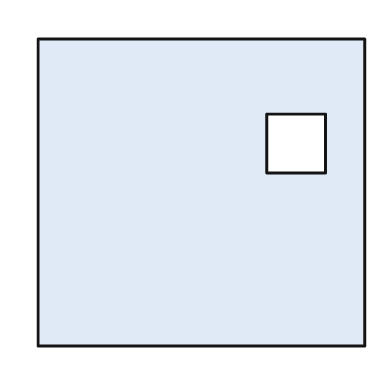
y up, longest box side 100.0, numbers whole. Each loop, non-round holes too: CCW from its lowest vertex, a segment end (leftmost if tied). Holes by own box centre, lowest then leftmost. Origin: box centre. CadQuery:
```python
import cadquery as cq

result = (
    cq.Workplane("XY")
    .moveTo(-50.0, -47.0)
    .lineTo(50.0, -47.0)
    .lineTo(50.0, 47.0)
    .lineTo(-50.0, 47.0)
    .close()
    .moveTo(20.0, 6.0)
    .lineTo(38.0, 6.0)
    .lineTo(38.0, 24.0)
    .lineTo(20.0, 24.0)
    .close()
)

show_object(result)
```